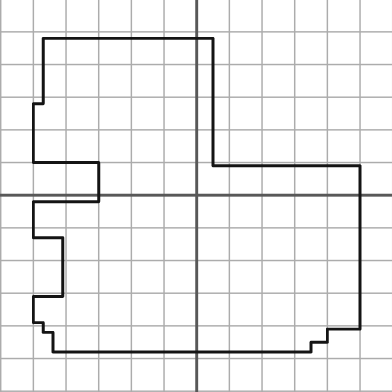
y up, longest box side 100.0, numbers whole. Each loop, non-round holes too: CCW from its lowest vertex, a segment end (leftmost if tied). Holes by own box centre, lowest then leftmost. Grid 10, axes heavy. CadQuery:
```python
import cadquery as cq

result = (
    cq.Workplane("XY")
    .moveTo(-44.0, -48.0)
    .lineTo(35.0, -48.0)
    .lineTo(35.0, -45.0)
    .lineTo(40.0, -45.0)
    .lineTo(40.0, -41.0)
    .lineTo(50.0, -41.0)
    .lineTo(50.0, 9.0)
    .lineTo(5.0, 9.0)
    .lineTo(5.0, 48.0)
    .lineTo(-47.0, 48.0)
    .lineTo(-47.0, 28.0)
    .lineTo(-50.0, 28.0)
    .lineTo(-50.0, 10.0)
    .lineTo(-30.0, 10.0)
    .lineTo(-30.0, -2.0)
    .lineTo(-50.0, -2.0)
    .lineTo(-50.0, -13.0)
    .lineTo(-41.0, -13.0)
    .lineTo(-41.0, -31.0)
    .lineTo(-50.0, -31.0)
    .lineTo(-50.0, -39.0)
    .lineTo(-47.0, -39.0)
    .lineTo(-47.0, -42.0)
    .lineTo(-44.0, -42.0)
    .close()
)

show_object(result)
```